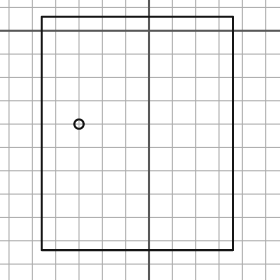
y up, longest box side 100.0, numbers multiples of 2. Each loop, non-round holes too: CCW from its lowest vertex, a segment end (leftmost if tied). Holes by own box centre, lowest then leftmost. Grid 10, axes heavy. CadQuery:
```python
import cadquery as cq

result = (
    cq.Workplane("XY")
    .moveTo(-46.0, -94.0)
    .lineTo(36.0, -94.0)
    .lineTo(36.0, 6.0)
    .lineTo(-46.0, 6.0)
    .close()
    .moveTo(-30.0, -40.0)
    .circle(2.0)
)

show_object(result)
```